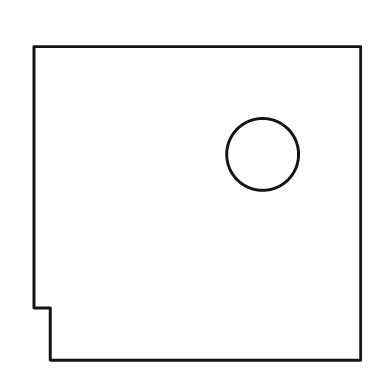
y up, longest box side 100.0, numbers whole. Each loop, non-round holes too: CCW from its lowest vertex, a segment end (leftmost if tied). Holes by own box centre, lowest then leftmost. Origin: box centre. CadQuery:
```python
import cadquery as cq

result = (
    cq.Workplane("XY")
    .moveTo(-45.0, -48.0)
    .lineTo(50.0, -48.0)
    .lineTo(50.0, 48.0)
    .lineTo(-50.0, 48.0)
    .lineTo(-50.0, -32.0)
    .lineTo(-45.0, -32.0)
    .close()
    .moveTo(20.0, 15.0)
    .circle(11.0)
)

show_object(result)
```